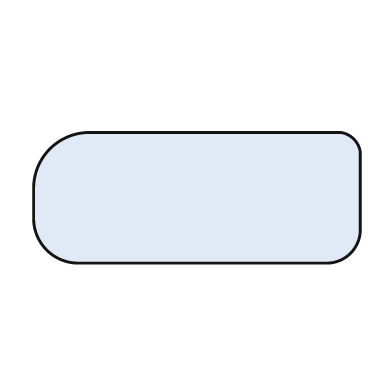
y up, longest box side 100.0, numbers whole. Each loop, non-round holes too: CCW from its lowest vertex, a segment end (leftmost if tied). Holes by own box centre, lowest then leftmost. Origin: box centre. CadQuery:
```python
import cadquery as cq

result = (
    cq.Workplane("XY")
    .moveTo(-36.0, -20.0)
    .lineTo(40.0, -20.0)
    .threePointArc((47.0, -17.0), (50.0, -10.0))
    .lineTo(50.0, 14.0)
    .threePointArc((48.0, 18.0), (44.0, 20.0))
    .lineTo(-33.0, 20.0)
    .threePointArc((-45.0, 15.0), (-50.0, 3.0))
    .lineTo(-50.0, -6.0)
    .threePointArc((-46.0, -16.0), (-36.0, -20.0))
    .close()
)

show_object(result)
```